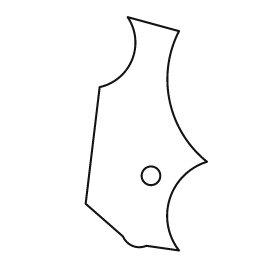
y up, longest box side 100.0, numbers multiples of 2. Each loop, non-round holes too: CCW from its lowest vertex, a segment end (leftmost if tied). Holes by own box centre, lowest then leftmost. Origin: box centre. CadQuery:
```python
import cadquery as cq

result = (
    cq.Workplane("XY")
    .moveTo(14.0, -50.0)
    .threePointArc((10.0, -28.0), (26.0, -12.0))
    .threePointArc((10.0, 14.0), (14.0, 44.0))
    .lineTo(-8.0, 50.0)
    .threePointArc((-6.0, 32.0), (-20.0, 20.0))
    .lineTo(-26.0, -30.0)
    .lineTo(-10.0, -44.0)
    .threePointArc((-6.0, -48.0), (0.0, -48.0))
    .close()
    .moveTo(2.0, -18.0)
    .circle(4.0)
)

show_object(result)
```